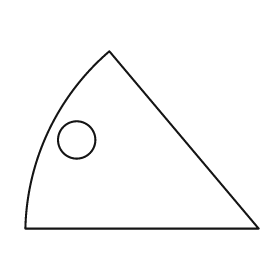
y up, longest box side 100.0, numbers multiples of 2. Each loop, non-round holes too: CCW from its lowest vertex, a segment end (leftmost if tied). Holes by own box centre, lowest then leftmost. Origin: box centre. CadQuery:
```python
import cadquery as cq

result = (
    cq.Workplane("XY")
    .moveTo(-50.0, -38.0)
    .lineTo(50.0, -38.0)
    .lineTo(-14.0, 38.0)
    .threePointArc((-40.0, 4.0), (-50.0, -38.0))
    .close()
    .moveTo(-28.0, 0.0)
    .circle(8.0)
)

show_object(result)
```